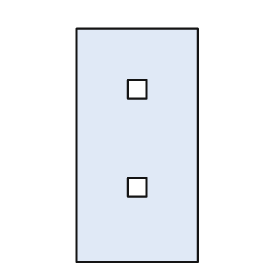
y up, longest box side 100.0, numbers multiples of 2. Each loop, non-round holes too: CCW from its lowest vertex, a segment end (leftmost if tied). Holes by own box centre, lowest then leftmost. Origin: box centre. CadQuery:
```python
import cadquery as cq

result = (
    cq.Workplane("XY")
    .moveTo(-26.0, -50.0)
    .lineTo(26.0, -50.0)
    .lineTo(26.0, 50.0)
    .lineTo(-26.0, 50.0)
    .close()
    .moveTo(-4.0, -22.0)
    .lineTo(4.0, -22.0)
    .lineTo(4.0, -14.0)
    .lineTo(-4.0, -14.0)
    .close()
    .moveTo(-4.0, 20.0)
    .lineTo(4.0, 20.0)
    .lineTo(4.0, 28.0)
    .lineTo(-4.0, 28.0)
    .close()
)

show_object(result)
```